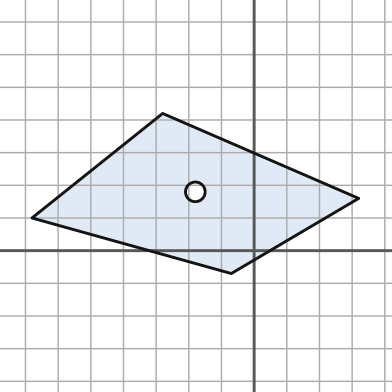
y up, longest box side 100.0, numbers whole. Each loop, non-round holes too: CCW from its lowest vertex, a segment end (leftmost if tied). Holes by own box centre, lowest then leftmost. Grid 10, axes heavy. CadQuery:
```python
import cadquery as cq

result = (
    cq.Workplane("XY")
    .moveTo(-7.0, -7.0)
    .lineTo(32.0, 16.0)
    .lineTo(-28.0, 42.0)
    .lineTo(-68.0, 10.0)
    .close()
    .moveTo(-18.0, 18.0)
    .circle(3.0)
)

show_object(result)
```